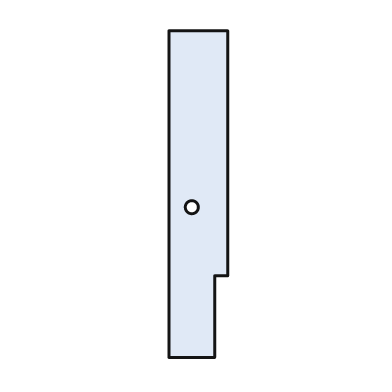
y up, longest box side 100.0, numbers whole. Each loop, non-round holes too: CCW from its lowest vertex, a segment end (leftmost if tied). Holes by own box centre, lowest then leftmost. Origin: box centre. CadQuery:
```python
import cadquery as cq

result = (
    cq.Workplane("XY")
    .moveTo(-9.0, -50.0)
    .lineTo(5.0, -50.0)
    .lineTo(5.0, -25.0)
    .lineTo(9.0, -25.0)
    .lineTo(9.0, 50.0)
    .lineTo(-9.0, 50.0)
    .close()
    .moveTo(-2.0, -4.0)
    .circle(2.0)
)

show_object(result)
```